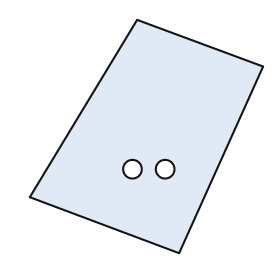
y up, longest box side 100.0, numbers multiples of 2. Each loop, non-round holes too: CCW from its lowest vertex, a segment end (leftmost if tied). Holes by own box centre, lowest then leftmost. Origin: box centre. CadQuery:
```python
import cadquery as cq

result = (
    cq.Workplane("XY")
    .moveTo(14.0, -50.0)
    .lineTo(50.0, 30.0)
    .lineTo(-4.0, 50.0)
    .lineTo(-50.0, -26.0)
    .close()
    .moveTo(-6.0, -14.0)
    .circle(4.0)
    .moveTo(8.0, -14.0)
    .circle(4.0)
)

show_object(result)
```